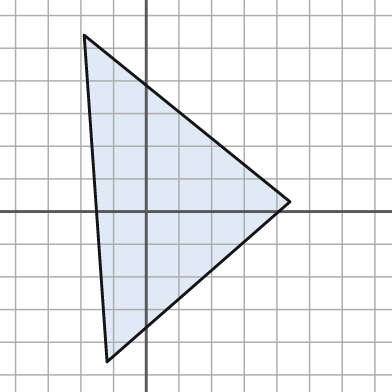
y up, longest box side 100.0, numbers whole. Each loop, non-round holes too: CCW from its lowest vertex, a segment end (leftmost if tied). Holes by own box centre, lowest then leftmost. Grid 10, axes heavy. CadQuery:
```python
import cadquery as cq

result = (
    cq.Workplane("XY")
    .moveTo(-12.0, -46.0)
    .lineTo(44.0, 3.0)
    .lineTo(-19.0, 54.0)
    .close()
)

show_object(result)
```